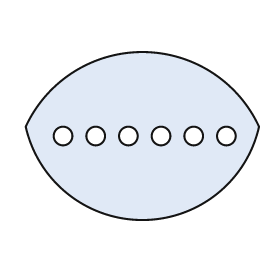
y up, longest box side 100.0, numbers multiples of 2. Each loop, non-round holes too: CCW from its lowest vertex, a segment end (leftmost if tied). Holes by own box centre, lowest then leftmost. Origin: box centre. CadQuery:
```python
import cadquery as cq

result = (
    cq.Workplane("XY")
    .moveTo(-50.0, 4.0)
    .threePointArc((0.0, -36.0), (50.0, 4.0))
    .threePointArc((0.0, 36.0), (-50.0, 4.0))
    .close()
    .moveTo(-34.0, 0.0)
    .circle(4.0)
    .moveTo(-20.0, 0.0)
    .circle(4.0)
    .moveTo(-6.0, 0.0)
    .circle(4.0)
    .moveTo(8.0, 0.0)
    .circle(4.0)
    .moveTo(22.0, 0.0)
    .circle(4.0)
    .moveTo(36.0, 0.0)
    .circle(4.0)
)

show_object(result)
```